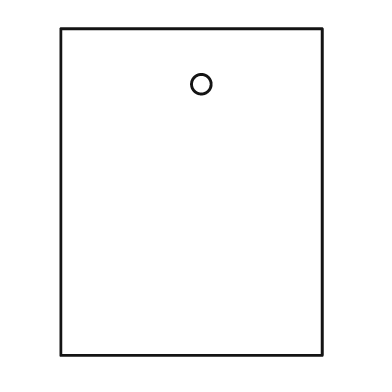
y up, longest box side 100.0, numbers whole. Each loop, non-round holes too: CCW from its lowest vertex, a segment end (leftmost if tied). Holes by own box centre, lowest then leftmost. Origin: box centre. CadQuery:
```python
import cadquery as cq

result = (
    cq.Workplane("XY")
    .moveTo(-40.0, -50.0)
    .lineTo(40.0, -50.0)
    .lineTo(40.0, 50.0)
    .lineTo(-40.0, 50.0)
    .close()
    .moveTo(3.0, 33.0)
    .circle(3.0)
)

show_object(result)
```